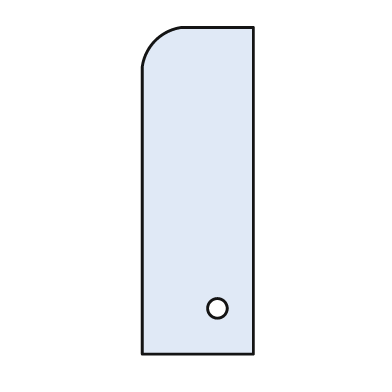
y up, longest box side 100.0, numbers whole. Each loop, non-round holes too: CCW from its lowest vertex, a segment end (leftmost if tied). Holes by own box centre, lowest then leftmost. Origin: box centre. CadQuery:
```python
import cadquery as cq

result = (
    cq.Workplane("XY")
    .moveTo(-17.0, -50.0)
    .lineTo(17.0, -50.0)
    .lineTo(17.0, 50.0)
    .lineTo(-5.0, 50.0)
    .threePointArc((-13.0, 46.0), (-17.0, 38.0))
    .close()
    .moveTo(6.0, -36.0)
    .circle(3.0)
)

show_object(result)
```